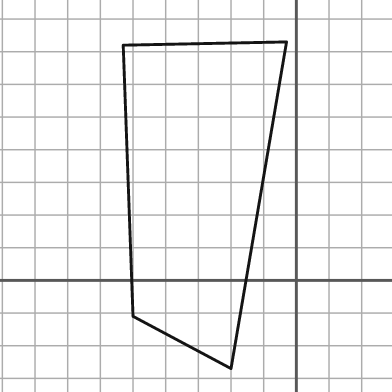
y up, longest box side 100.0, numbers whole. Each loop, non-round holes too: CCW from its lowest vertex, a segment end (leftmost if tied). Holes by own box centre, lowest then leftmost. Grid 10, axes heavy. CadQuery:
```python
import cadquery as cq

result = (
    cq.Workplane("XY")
    .moveTo(-20.0, -27.0)
    .lineTo(-3.0, 73.0)
    .lineTo(-53.0, 72.0)
    .lineTo(-50.0, -11.0)
    .close()
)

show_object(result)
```